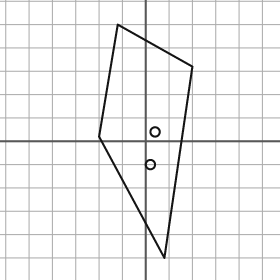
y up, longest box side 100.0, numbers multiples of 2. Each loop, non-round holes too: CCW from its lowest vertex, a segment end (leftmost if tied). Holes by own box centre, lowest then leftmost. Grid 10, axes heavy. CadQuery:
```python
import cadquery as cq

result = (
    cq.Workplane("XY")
    .moveTo(8.0, -50.0)
    .lineTo(20.0, 32.0)
    .lineTo(-12.0, 50.0)
    .lineTo(-20.0, 2.0)
    .close()
    .moveTo(2.0, -10.0)
    .circle(2.0)
    .moveTo(4.0, 4.0)
    .circle(2.0)
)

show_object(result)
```